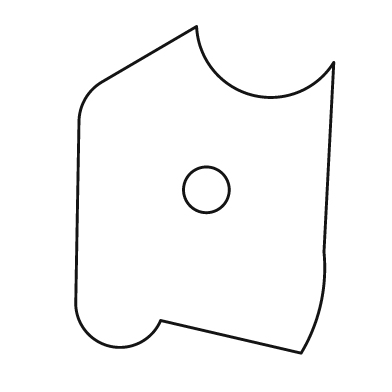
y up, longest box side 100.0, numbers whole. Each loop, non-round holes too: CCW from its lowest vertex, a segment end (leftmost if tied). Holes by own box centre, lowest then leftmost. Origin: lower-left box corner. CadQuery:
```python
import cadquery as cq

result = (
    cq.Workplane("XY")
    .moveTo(69.0, 0.0)
    .threePointArc((75.0, 15.0), (76.0, 31.0))
    .lineTo(79.0, 89.0)
    .threePointArc((54.0, 79.0), (37.0, 100.0))
    .lineTo(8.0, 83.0)
    .threePointArc((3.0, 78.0), (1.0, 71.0))
    .lineTo(0.0, 15.0)
    .threePointArc((11.0, 2.0), (26.0, 10.0))
    .close()
    .moveTo(40.0, 50.0)
    .circle(7.0)
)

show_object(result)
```